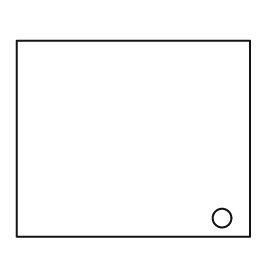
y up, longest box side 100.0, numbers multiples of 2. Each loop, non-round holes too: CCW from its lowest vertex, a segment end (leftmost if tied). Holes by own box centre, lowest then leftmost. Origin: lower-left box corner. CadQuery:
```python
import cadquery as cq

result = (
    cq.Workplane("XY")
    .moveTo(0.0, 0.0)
    .lineTo(100.0, 0.0)
    .lineTo(100.0, 84.0)
    .lineTo(0.0, 84.0)
    .close()
    .moveTo(88.0, 8.0)
    .circle(4.0)
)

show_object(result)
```